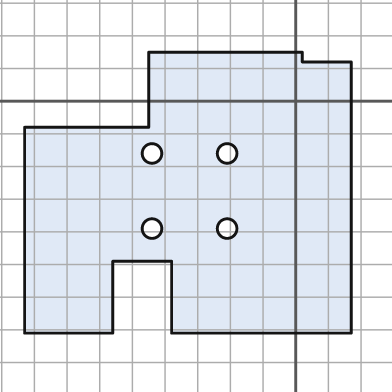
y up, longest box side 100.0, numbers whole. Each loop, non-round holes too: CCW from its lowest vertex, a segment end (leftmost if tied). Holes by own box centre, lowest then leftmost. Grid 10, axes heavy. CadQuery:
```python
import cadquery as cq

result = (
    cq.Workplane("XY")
    .moveTo(-83.0, -71.0)
    .lineTo(-56.0, -71.0)
    .lineTo(-56.0, -49.0)
    .lineTo(-38.0, -49.0)
    .lineTo(-38.0, -71.0)
    .lineTo(17.0, -71.0)
    .lineTo(17.0, 12.0)
    .lineTo(2.0, 12.0)
    .lineTo(2.0, 15.0)
    .lineTo(-45.0, 15.0)
    .lineTo(-45.0, -8.0)
    .lineTo(-83.0, -8.0)
    .close()
    .moveTo(-44.0, -39.0)
    .circle(3.0)
    .moveTo(-21.0, -39.0)
    .circle(3.0)
    .moveTo(-44.0, -16.0)
    .circle(3.0)
    .moveTo(-21.0, -16.0)
    .circle(3.0)
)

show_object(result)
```